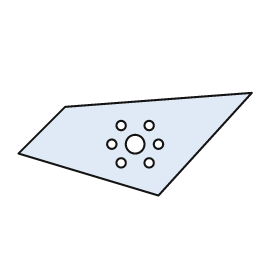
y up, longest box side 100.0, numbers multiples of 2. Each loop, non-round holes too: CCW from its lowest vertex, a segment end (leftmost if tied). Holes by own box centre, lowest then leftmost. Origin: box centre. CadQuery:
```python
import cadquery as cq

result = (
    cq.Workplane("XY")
    .moveTo(10.0, -22.0)
    .lineTo(50.0, 22.0)
    .lineTo(-30.0, 16.0)
    .lineTo(-50.0, -4.0)
    .close()
    .moveTo(-6.0, -8.0)
    .circle(2.0)
    .moveTo(6.0, -8.0)
    .circle(2.0)
    .moveTo(-10.0, 0.0)
    .circle(2.0)
    .moveTo(0.0, 0.0)
    .circle(4.0)
    .moveTo(10.0, 0.0)
    .circle(2.0)
    .moveTo(-6.0, 8.0)
    .circle(2.0)
    .moveTo(6.0, 8.0)
    .circle(2.0)
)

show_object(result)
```